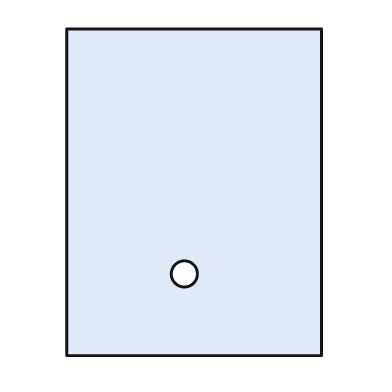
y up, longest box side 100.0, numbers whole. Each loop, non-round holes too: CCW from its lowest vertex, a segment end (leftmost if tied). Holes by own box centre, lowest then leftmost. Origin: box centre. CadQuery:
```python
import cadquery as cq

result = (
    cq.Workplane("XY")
    .moveTo(-39.0, -50.0)
    .lineTo(39.0, -50.0)
    .lineTo(39.0, 50.0)
    .lineTo(-39.0, 50.0)
    .close()
    .moveTo(-3.0, -25.0)
    .circle(4.0)
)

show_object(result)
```